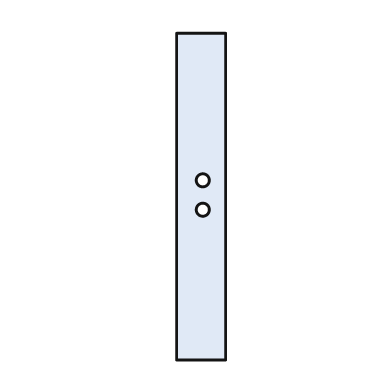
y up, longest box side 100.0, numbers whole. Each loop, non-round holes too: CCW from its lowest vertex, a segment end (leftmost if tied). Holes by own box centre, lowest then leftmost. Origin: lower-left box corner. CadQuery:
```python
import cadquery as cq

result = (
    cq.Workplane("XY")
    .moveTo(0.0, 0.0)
    .lineTo(15.0, 0.0)
    .lineTo(15.0, 100.0)
    .lineTo(0.0, 100.0)
    .close()
    .moveTo(8.0, 46.0)
    .circle(2.0)
    .moveTo(8.0, 55.0)
    .circle(2.0)
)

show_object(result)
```